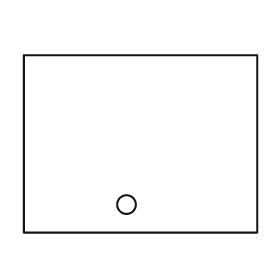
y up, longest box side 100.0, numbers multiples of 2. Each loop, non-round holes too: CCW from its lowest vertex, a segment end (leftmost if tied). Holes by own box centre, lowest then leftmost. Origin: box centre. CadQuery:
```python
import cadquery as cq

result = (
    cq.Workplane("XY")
    .moveTo(-50.0, -38.0)
    .lineTo(50.0, -38.0)
    .lineTo(50.0, 38.0)
    .lineTo(-50.0, 38.0)
    .close()
    .moveTo(-6.0, -26.0)
    .circle(4.0)
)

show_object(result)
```